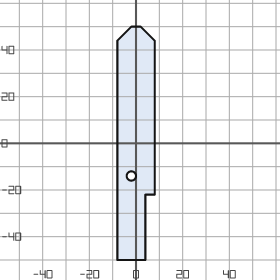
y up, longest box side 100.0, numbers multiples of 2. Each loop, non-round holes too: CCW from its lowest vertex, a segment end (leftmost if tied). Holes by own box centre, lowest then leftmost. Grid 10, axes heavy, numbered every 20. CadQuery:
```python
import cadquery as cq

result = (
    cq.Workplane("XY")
    .moveTo(-8.0, -50.0)
    .lineTo(4.0, -50.0)
    .lineTo(4.0, -22.0)
    .lineTo(8.0, -22.0)
    .lineTo(8.0, 44.0)
    .lineTo(2.0, 50.0)
    .lineTo(-2.0, 50.0)
    .lineTo(-8.0, 44.0)
    .close()
    .moveTo(-2.0, -14.0)
    .circle(2.0)
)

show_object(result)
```